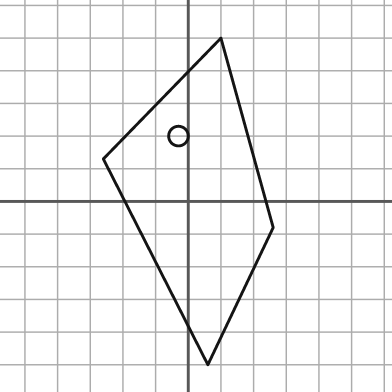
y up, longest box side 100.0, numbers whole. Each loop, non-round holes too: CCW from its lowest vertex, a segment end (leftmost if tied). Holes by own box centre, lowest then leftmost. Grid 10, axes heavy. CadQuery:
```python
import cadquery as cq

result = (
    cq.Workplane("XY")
    .moveTo(6.0, -50.0)
    .lineTo(26.0, -8.0)
    .lineTo(10.0, 50.0)
    .lineTo(-26.0, 13.0)
    .close()
    .moveTo(-3.0, 20.0)
    .circle(3.0)
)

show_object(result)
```